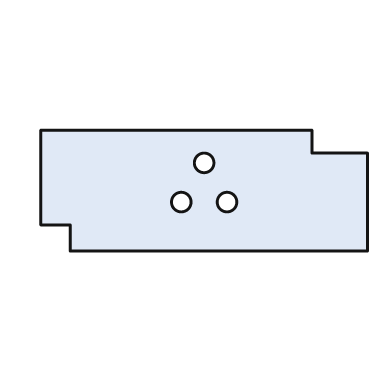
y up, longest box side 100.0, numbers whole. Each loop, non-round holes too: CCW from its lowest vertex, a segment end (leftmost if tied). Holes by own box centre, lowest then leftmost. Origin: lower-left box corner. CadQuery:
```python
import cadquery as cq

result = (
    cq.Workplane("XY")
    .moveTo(9.0, 0.0)
    .lineTo(100.0, 0.0)
    .lineTo(100.0, 30.0)
    .lineTo(83.0, 30.0)
    .lineTo(83.0, 37.0)
    .lineTo(0.0, 37.0)
    .lineTo(0.0, 8.0)
    .lineTo(9.0, 8.0)
    .close()
    .moveTo(43.0, 15.0)
    .circle(3.0)
    .moveTo(57.0, 15.0)
    .circle(3.0)
    .moveTo(50.0, 27.0)
    .circle(3.0)
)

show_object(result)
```